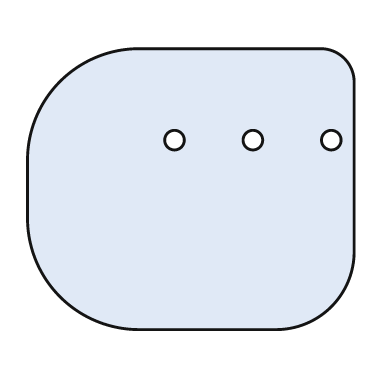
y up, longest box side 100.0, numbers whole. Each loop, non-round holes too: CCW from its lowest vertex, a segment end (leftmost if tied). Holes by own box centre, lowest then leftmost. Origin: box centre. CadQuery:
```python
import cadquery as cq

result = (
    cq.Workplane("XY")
    .moveTo(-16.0, -43.0)
    .lineTo(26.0, -43.0)
    .threePointArc((43.0, -36.0), (50.0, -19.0))
    .lineTo(50.0, 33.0)
    .threePointArc((47.0, 40.0), (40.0, 43.0))
    .lineTo(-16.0, 43.0)
    .threePointArc((-40.0, 33.0), (-50.0, 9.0))
    .lineTo(-50.0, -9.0)
    .threePointArc((-40.0, -33.0), (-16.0, -43.0))
    .close()
    .moveTo(-5.0, 15.0)
    .circle(3.0)
    .moveTo(19.0, 15.0)
    .circle(3.0)
    .moveTo(43.0, 15.0)
    .circle(3.0)
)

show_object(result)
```